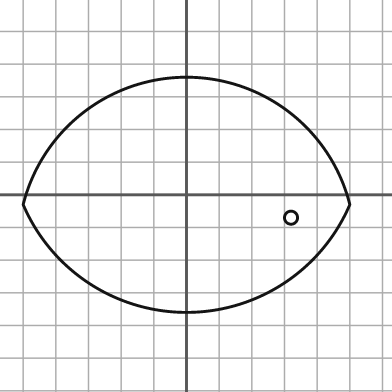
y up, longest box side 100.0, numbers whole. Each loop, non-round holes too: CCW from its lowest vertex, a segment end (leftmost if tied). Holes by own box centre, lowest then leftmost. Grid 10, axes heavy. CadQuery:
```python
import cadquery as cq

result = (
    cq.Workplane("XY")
    .moveTo(-50.0, -3.0)
    .threePointArc((0.0, -36.0), (50.0, -3.0))
    .threePointArc((0.0, 36.0), (-50.0, -3.0))
    .close()
    .moveTo(32.0, -7.0)
    .circle(2.0)
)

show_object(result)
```